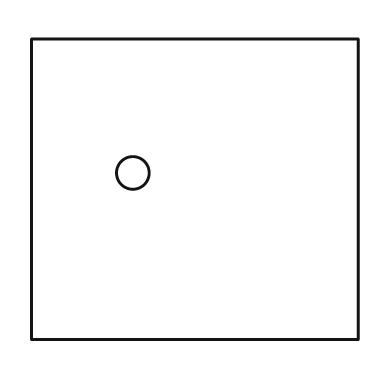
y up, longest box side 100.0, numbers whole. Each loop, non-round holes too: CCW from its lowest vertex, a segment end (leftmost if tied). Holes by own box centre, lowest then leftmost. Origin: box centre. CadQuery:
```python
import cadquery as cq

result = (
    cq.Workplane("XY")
    .moveTo(-50.0, -46.0)
    .lineTo(50.0, -46.0)
    .lineTo(50.0, 46.0)
    .lineTo(-50.0, 46.0)
    .close()
    .moveTo(-19.0, 5.0)
    .circle(5.0)
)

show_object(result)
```